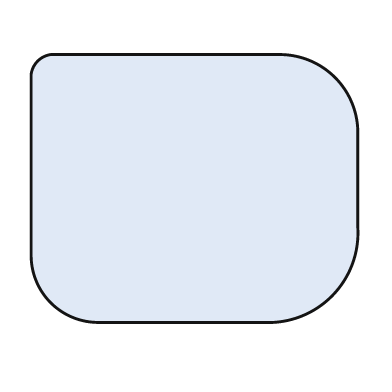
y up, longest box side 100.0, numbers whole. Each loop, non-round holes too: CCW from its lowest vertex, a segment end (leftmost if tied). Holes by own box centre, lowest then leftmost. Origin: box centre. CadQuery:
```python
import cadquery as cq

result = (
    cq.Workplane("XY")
    .moveTo(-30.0, -41.0)
    .lineTo(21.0, -41.0)
    .threePointArc((42.0, -33.0), (50.0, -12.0))
    .lineTo(50.0, 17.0)
    .threePointArc((43.0, 34.0), (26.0, 41.0))
    .lineTo(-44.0, 41.0)
    .threePointArc((-48.0, 39.0), (-50.0, 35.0))
    .lineTo(-50.0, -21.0)
    .threePointArc((-44.0, -35.0), (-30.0, -41.0))
    .close()
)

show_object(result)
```